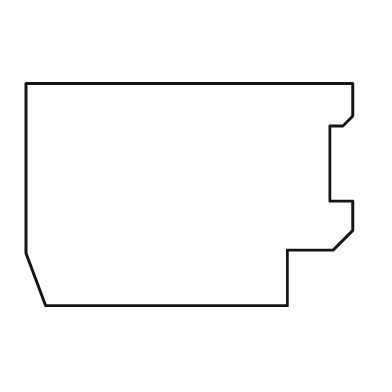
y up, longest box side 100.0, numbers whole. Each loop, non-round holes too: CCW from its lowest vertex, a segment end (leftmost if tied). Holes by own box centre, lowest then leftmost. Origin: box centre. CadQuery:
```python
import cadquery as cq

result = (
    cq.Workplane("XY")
    .moveTo(-44.0, -34.0)
    .lineTo(30.0, -34.0)
    .lineTo(30.0, -17.0)
    .lineTo(44.0, -17.0)
    .lineTo(50.0, -11.0)
    .lineTo(50.0, -2.0)
    .lineTo(43.0, -2.0)
    .lineTo(43.0, 21.0)
    .lineTo(47.0, 21.0)
    .lineTo(50.0, 24.0)
    .lineTo(50.0, 34.0)
    .lineTo(-50.0, 34.0)
    .lineTo(-50.0, -18.0)
    .close()
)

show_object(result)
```